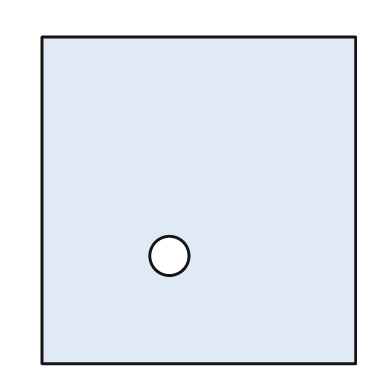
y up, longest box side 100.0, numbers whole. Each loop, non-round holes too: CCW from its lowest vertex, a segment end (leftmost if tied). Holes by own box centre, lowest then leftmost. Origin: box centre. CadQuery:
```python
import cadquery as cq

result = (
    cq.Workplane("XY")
    .moveTo(-48.0, -50.0)
    .lineTo(48.0, -50.0)
    .lineTo(48.0, 50.0)
    .lineTo(-48.0, 50.0)
    .close()
    .moveTo(-9.0, -17.0)
    .circle(6.0)
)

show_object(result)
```